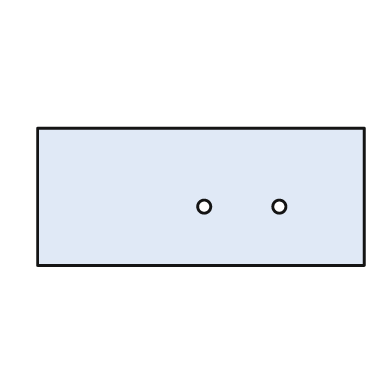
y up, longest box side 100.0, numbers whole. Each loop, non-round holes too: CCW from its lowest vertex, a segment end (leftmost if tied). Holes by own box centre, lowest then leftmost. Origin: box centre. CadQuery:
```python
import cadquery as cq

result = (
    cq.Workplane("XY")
    .moveTo(-50.0, -21.0)
    .lineTo(50.0, -21.0)
    .lineTo(50.0, 21.0)
    .lineTo(-50.0, 21.0)
    .close()
    .moveTo(1.0, -3.0)
    .circle(2.0)
    .moveTo(24.0, -3.0)
    .circle(2.0)
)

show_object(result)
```